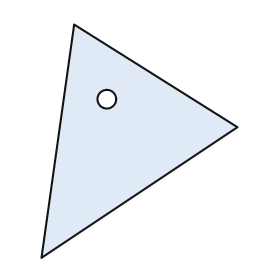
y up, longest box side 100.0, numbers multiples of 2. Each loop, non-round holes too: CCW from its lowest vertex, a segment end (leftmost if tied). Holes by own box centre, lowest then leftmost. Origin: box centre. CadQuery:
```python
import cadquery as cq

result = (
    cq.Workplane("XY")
    .moveTo(-42.0, -50.0)
    .lineTo(42.0, 6.0)
    .lineTo(-28.0, 50.0)
    .close()
    .moveTo(-14.0, 18.0)
    .circle(4.0)
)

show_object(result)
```